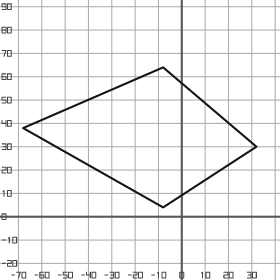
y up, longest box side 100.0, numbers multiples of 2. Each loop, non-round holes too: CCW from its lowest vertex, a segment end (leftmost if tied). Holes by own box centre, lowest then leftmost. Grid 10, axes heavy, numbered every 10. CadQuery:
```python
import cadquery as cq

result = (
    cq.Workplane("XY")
    .moveTo(-8.0, 4.0)
    .lineTo(32.0, 30.0)
    .lineTo(-8.0, 64.0)
    .lineTo(-68.0, 38.0)
    .close()
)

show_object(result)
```